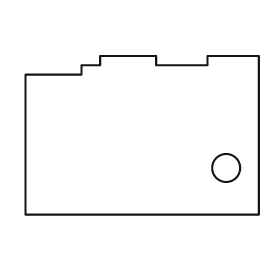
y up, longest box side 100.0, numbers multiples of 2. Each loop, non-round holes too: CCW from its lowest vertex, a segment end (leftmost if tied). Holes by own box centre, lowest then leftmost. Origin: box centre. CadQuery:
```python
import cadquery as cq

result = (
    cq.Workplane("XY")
    .moveTo(-50.0, -34.0)
    .lineTo(50.0, -34.0)
    .lineTo(50.0, 34.0)
    .lineTo(28.0, 34.0)
    .lineTo(28.0, 30.0)
    .lineTo(6.0, 30.0)
    .lineTo(6.0, 34.0)
    .lineTo(-18.0, 34.0)
    .lineTo(-18.0, 30.0)
    .lineTo(-26.0, 30.0)
    .lineTo(-26.0, 26.0)
    .lineTo(-50.0, 26.0)
    .close()
    .moveTo(36.0, -14.0)
    .circle(6.0)
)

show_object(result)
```